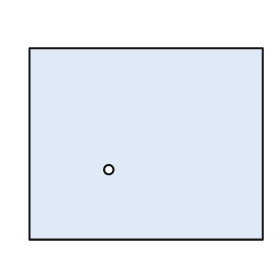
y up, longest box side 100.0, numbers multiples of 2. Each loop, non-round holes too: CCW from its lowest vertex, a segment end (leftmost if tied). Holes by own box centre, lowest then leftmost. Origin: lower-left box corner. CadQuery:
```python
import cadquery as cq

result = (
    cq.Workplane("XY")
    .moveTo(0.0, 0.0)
    .lineTo(100.0, 0.0)
    .lineTo(100.0, 82.0)
    .lineTo(0.0, 82.0)
    .close()
    .moveTo(34.0, 30.0)
    .circle(2.0)
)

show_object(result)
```